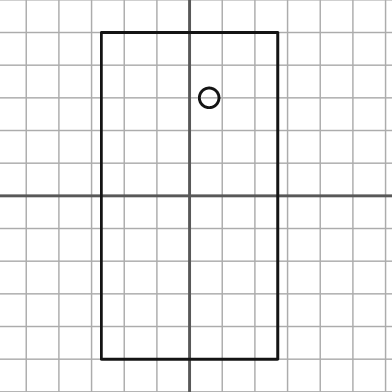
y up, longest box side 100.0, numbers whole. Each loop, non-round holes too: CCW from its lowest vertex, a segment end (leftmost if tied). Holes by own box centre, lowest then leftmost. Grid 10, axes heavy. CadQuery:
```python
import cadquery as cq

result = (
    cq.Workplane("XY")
    .moveTo(-27.0, -50.0)
    .lineTo(27.0, -50.0)
    .lineTo(27.0, 50.0)
    .lineTo(-27.0, 50.0)
    .close()
    .moveTo(6.0, 30.0)
    .circle(3.0)
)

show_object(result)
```